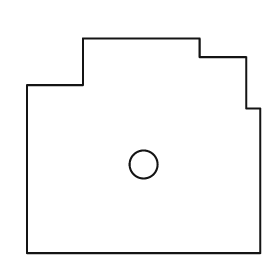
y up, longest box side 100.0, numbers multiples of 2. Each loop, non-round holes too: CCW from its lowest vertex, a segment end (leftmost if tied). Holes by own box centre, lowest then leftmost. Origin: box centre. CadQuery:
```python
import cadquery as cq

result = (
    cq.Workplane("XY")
    .moveTo(-50.0, -46.0)
    .lineTo(50.0, -46.0)
    .lineTo(50.0, 16.0)
    .lineTo(44.0, 16.0)
    .lineTo(44.0, 38.0)
    .lineTo(24.0, 38.0)
    .lineTo(24.0, 46.0)
    .lineTo(-26.0, 46.0)
    .lineTo(-26.0, 26.0)
    .lineTo(-50.0, 26.0)
    .close()
    .moveTo(0.0, -8.0)
    .circle(6.0)
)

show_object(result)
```